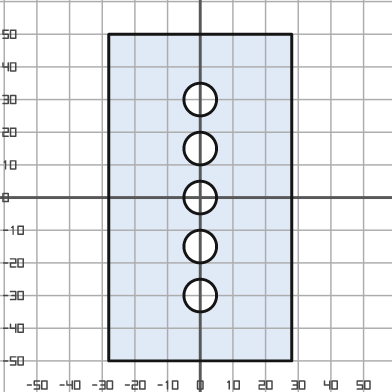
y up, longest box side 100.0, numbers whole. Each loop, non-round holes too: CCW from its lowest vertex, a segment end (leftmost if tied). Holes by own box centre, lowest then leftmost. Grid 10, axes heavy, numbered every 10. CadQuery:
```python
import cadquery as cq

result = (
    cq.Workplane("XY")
    .moveTo(-28.0, -50.0)
    .lineTo(28.0, -50.0)
    .lineTo(28.0, 50.0)
    .lineTo(-28.0, 50.0)
    .close()
    .moveTo(0.0, -30.0)
    .circle(5.0)
    .moveTo(0.0, -15.0)
    .circle(5.0)
    .moveTo(0.0, 0.0)
    .circle(5.0)
    .moveTo(0.0, 15.0)
    .circle(5.0)
    .moveTo(0.0, 30.0)
    .circle(5.0)
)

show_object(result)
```